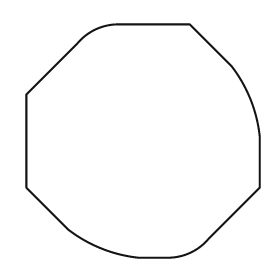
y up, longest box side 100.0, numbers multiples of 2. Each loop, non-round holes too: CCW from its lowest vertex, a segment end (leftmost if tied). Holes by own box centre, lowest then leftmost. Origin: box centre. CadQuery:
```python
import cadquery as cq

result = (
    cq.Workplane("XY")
    .moveTo(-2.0, -50.0)
    .lineTo(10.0, -50.0)
    .threePointArc((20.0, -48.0), (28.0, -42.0))
    .lineTo(50.0, -20.0)
    .lineTo(50.0, 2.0)
    .threePointArc((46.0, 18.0), (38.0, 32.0))
    .lineTo(20.0, 50.0)
    .lineTo(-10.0, 50.0)
    .threePointArc((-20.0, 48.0), (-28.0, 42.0))
    .lineTo(-50.0, 20.0)
    .lineTo(-50.0, -20.0)
    .lineTo(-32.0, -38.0)
    .threePointArc((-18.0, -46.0), (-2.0, -50.0))
    .close()
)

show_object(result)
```